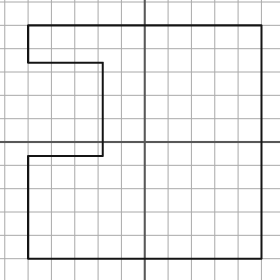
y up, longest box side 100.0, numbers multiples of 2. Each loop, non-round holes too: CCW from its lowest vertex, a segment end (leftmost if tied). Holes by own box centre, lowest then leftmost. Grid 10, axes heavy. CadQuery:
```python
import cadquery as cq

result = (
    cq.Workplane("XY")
    .moveTo(-50.0, -50.0)
    .lineTo(50.0, -50.0)
    .lineTo(50.0, 50.0)
    .lineTo(-50.0, 50.0)
    .lineTo(-50.0, 34.0)
    .lineTo(-18.0, 34.0)
    .lineTo(-18.0, -6.0)
    .lineTo(-50.0, -6.0)
    .close()
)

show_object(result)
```